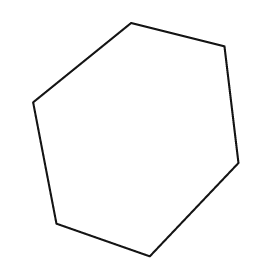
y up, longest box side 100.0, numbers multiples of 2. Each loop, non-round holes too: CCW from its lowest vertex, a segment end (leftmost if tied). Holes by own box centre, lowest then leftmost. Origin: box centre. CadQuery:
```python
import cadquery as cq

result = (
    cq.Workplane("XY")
    .moveTo(6.0, -50.0)
    .lineTo(44.0, -10.0)
    .lineTo(38.0, 40.0)
    .lineTo(-2.0, 50.0)
    .lineTo(-44.0, 16.0)
    .lineTo(-34.0, -36.0)
    .close()
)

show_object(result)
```